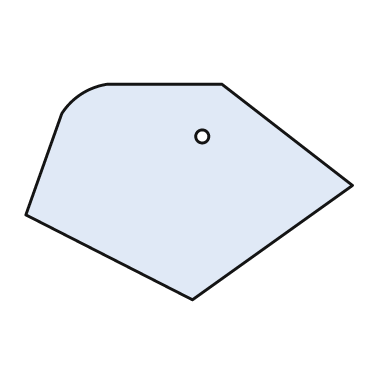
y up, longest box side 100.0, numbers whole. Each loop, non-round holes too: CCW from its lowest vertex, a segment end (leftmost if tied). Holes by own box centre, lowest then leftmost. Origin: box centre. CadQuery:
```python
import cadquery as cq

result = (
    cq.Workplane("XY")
    .moveTo(1.0, -33.0)
    .lineTo(50.0, 2.0)
    .lineTo(10.0, 33.0)
    .lineTo(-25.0, 33.0)
    .threePointArc((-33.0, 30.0), (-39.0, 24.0))
    .lineTo(-50.0, -7.0)
    .close()
    .moveTo(4.0, 17.0)
    .circle(2.0)
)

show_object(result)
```